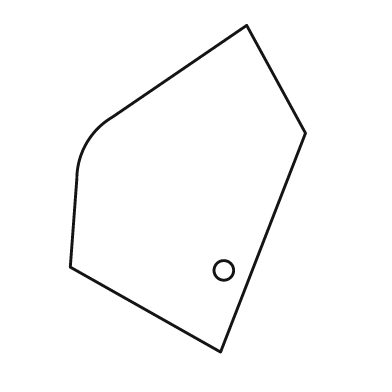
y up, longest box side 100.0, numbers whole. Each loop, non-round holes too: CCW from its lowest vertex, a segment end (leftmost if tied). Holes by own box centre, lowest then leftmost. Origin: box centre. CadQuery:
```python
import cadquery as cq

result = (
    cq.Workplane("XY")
    .moveTo(10.0, -50.0)
    .lineTo(36.0, 17.0)
    .lineTo(18.0, 50.0)
    .lineTo(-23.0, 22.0)
    .threePointArc((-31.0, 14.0), (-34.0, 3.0))
    .lineTo(-36.0, -24.0)
    .close()
    .moveTo(11.0, -25.0)
    .circle(3.0)
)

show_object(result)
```